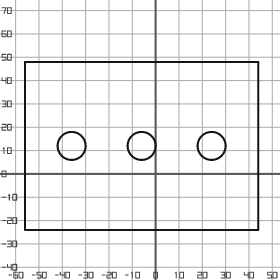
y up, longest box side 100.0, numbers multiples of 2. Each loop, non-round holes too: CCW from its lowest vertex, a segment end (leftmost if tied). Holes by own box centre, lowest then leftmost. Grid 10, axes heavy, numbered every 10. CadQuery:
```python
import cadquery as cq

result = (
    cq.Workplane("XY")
    .moveTo(-56.0, -24.0)
    .lineTo(44.0, -24.0)
    .lineTo(44.0, 48.0)
    .lineTo(-56.0, 48.0)
    .close()
    .moveTo(-36.0, 12.0)
    .circle(6.0)
    .moveTo(-6.0, 12.0)
    .circle(6.0)
    .moveTo(24.0, 12.0)
    .circle(6.0)
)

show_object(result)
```